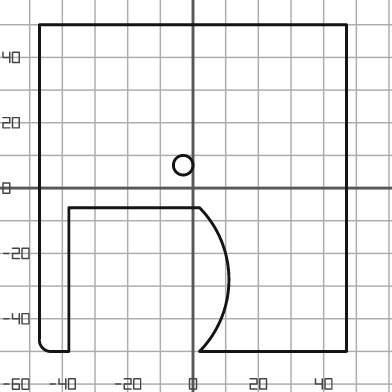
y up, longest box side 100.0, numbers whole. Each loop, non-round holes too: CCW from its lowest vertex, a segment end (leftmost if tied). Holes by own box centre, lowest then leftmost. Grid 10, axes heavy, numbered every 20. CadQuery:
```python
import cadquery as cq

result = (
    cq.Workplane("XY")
    .moveTo(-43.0, -50.0)
    .lineTo(-38.0, -50.0)
    .lineTo(-38.0, -6.0)
    .lineTo(2.0, -6.0)
    .threePointArc((11.0, -28.0), (2.0, -50.0))
    .lineTo(47.0, -50.0)
    .lineTo(47.0, 50.0)
    .lineTo(-47.0, 50.0)
    .lineTo(-47.0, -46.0)
    .threePointArc((-46.0, -49.0), (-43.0, -50.0))
    .close()
    .moveTo(-3.0, 7.0)
    .circle(3.0)
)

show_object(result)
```